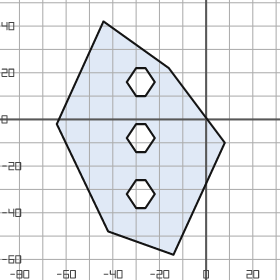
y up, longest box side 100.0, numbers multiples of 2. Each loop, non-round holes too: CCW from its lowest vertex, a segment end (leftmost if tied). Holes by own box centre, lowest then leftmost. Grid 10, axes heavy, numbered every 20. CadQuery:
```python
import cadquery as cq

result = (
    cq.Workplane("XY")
    .moveTo(-14.0, -58.0)
    .lineTo(8.0, -10.0)
    .lineTo(-16.0, 22.0)
    .lineTo(-44.0, 42.0)
    .lineTo(-64.0, -2.0)
    .lineTo(-42.0, -48.0)
    .close()
    .moveTo(-30.0, -38.0)
    .lineTo(-26.0, -38.0)
    .lineTo(-22.0, -32.0)
    .lineTo(-26.0, -26.0)
    .lineTo(-30.0, -26.0)
    .lineTo(-34.0, -32.0)
    .close()
    .moveTo(-30.0, -14.0)
    .lineTo(-26.0, -14.0)
    .lineTo(-22.0, -8.0)
    .lineTo(-26.0, -2.0)
    .lineTo(-30.0, -2.0)
    .lineTo(-34.0, -8.0)
    .close()
    .moveTo(-30.0, 10.0)
    .lineTo(-26.0, 10.0)
    .lineTo(-22.0, 16.0)
    .lineTo(-26.0, 22.0)
    .lineTo(-30.0, 22.0)
    .lineTo(-34.0, 16.0)
    .close()
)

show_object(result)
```